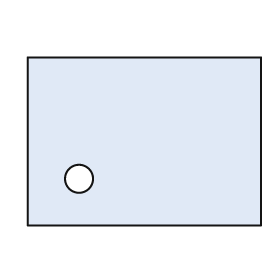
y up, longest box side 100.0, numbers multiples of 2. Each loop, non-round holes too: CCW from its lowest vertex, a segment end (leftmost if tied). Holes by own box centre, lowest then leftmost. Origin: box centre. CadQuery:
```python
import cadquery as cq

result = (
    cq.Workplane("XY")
    .moveTo(-50.0, -36.0)
    .lineTo(50.0, -36.0)
    .lineTo(50.0, 36.0)
    .lineTo(-50.0, 36.0)
    .close()
    .moveTo(-28.0, -16.0)
    .circle(6.0)
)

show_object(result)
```